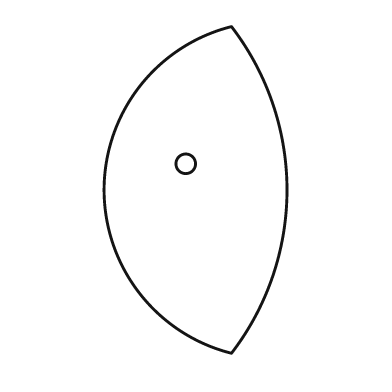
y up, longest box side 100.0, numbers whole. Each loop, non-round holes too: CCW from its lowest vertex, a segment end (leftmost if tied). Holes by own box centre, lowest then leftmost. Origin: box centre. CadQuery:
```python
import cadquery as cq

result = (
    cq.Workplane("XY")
    .moveTo(11.0, -50.0)
    .threePointArc((28.0, 0.0), (11.0, 50.0))
    .threePointArc((-28.0, 0.0), (11.0, -50.0))
    .close()
    .moveTo(-3.0, 8.0)
    .circle(3.0)
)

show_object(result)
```